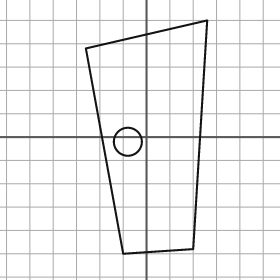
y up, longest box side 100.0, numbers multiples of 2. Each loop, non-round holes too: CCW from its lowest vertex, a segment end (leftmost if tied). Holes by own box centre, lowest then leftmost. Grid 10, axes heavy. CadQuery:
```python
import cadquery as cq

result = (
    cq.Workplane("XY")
    .moveTo(-10.0, -50.0)
    .lineTo(20.0, -48.0)
    .lineTo(26.0, 50.0)
    .lineTo(-26.0, 38.0)
    .close()
    .moveTo(-8.0, -2.0)
    .circle(6.0)
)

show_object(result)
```